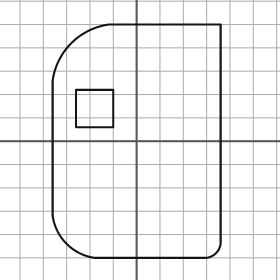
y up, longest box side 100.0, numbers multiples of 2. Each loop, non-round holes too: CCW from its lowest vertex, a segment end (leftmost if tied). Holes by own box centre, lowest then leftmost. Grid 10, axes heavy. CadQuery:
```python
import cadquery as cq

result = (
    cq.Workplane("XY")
    .moveTo(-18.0, -50.0)
    .lineTo(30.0, -50.0)
    .threePointArc((34.0, -48.0), (36.0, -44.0))
    .lineTo(36.0, 50.0)
    .lineTo(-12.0, 50.0)
    .threePointArc((-28.0, 42.0), (-36.0, 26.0))
    .lineTo(-36.0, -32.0)
    .threePointArc((-30.0, -44.0), (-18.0, -50.0))
    .close()
    .moveTo(-26.0, 6.0)
    .lineTo(-10.0, 6.0)
    .lineTo(-10.0, 22.0)
    .lineTo(-26.0, 22.0)
    .close()
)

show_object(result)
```